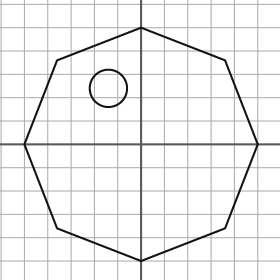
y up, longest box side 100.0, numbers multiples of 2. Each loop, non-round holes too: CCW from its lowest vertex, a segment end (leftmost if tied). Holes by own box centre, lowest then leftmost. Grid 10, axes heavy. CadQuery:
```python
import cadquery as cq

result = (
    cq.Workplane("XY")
    .moveTo(0.0, -50.0)
    .lineTo(36.0, -36.0)
    .lineTo(50.0, 0.0)
    .lineTo(36.0, 36.0)
    .lineTo(0.0, 50.0)
    .lineTo(-36.0, 36.0)
    .lineTo(-50.0, 0.0)
    .lineTo(-36.0, -36.0)
    .close()
    .moveTo(-14.0, 24.0)
    .circle(8.0)
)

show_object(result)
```